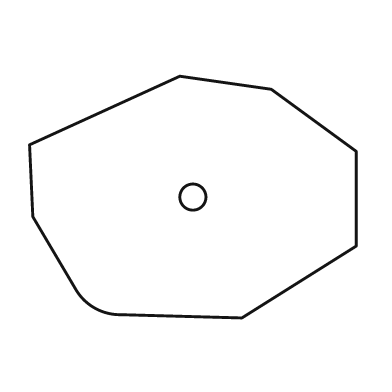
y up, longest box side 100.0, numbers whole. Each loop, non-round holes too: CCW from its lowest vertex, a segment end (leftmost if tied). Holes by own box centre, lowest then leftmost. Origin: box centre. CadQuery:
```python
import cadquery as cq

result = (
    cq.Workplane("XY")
    .moveTo(15.0, -37.0)
    .lineTo(50.0, -15.0)
    .lineTo(50.0, 14.0)
    .lineTo(24.0, 33.0)
    .lineTo(-4.0, 37.0)
    .lineTo(-50.0, 16.0)
    .lineTo(-49.0, -6.0)
    .lineTo(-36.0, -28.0)
    .threePointArc((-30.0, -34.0), (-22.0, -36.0))
    .close()
    .moveTo(0.0, 0.0)
    .circle(4.0)
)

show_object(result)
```